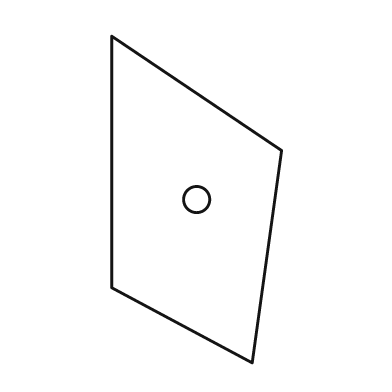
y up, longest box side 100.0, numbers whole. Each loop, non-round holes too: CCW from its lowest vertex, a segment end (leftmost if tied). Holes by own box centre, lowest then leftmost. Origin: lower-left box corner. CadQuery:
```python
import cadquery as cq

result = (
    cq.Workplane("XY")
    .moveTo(43.0, 0.0)
    .lineTo(52.0, 65.0)
    .lineTo(0.0, 100.0)
    .lineTo(0.0, 23.0)
    .close()
    .moveTo(26.0, 50.0)
    .circle(4.0)
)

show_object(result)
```